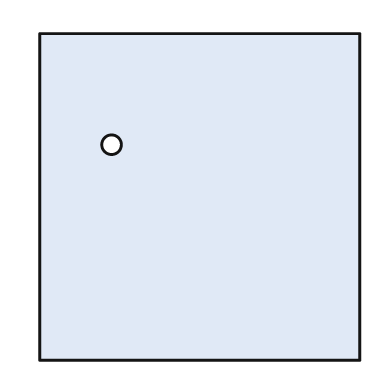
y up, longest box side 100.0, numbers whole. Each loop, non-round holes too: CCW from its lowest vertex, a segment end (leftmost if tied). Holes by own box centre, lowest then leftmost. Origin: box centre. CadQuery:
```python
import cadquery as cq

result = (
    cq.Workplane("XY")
    .moveTo(-49.0, -50.0)
    .lineTo(49.0, -50.0)
    .lineTo(49.0, 50.0)
    .lineTo(-49.0, 50.0)
    .close()
    .moveTo(-27.0, 16.0)
    .circle(3.0)
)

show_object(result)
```